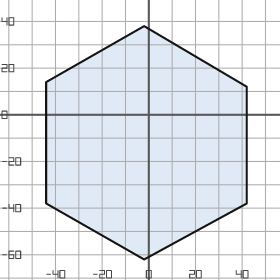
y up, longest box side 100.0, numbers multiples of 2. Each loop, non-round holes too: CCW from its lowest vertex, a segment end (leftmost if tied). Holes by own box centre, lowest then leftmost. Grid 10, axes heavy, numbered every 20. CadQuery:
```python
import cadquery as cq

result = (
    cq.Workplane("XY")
    .moveTo(-2.0, -62.0)
    .lineTo(42.0, -38.0)
    .lineTo(42.0, 12.0)
    .lineTo(-2.0, 38.0)
    .lineTo(-44.0, 14.0)
    .lineTo(-44.0, -38.0)
    .close()
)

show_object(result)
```